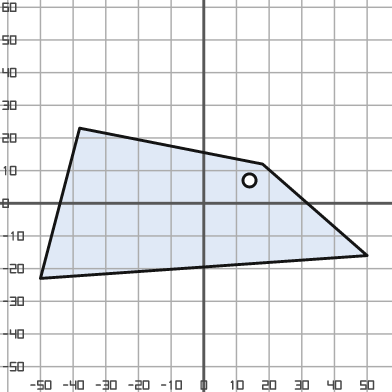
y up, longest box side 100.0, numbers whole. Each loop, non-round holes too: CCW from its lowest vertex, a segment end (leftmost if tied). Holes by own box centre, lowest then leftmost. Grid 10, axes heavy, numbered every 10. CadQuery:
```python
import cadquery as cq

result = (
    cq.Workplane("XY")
    .moveTo(-50.0, -23.0)
    .lineTo(50.0, -16.0)
    .lineTo(18.0, 12.0)
    .lineTo(-38.0, 23.0)
    .close()
    .moveTo(14.0, 7.0)
    .circle(2.0)
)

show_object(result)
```